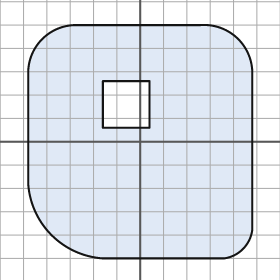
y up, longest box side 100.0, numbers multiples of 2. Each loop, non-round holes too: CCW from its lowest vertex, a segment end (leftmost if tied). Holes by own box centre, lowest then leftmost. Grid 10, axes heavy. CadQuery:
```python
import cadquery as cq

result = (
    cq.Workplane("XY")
    .moveTo(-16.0, -50.0)
    .lineTo(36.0, -50.0)
    .threePointArc((44.0, -46.0), (48.0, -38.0))
    .lineTo(48.0, 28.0)
    .threePointArc((42.0, 44.0), (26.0, 50.0))
    .lineTo(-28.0, 50.0)
    .threePointArc((-42.0, 44.0), (-48.0, 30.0))
    .lineTo(-48.0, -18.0)
    .threePointArc((-38.0, -40.0), (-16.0, -50.0))
    .close()
    .moveTo(-16.0, 6.0)
    .lineTo(4.0, 6.0)
    .lineTo(4.0, 26.0)
    .lineTo(-16.0, 26.0)
    .close()
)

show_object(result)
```